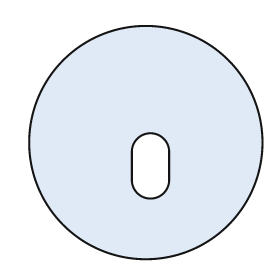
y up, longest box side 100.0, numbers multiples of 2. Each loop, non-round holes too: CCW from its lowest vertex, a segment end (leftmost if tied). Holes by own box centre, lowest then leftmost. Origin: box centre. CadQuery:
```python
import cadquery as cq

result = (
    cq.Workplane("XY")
    .moveTo(0.0, 0.0)
    .circle(50.0)
    .moveTo(-6.0, -16.0)
    .threePointArc((2.0, -24.0), (10.0, -16.0))
    .lineTo(10.0, -4.0)
    .threePointArc((2.0, 4.0), (-6.0, -4.0))
    .close()
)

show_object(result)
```